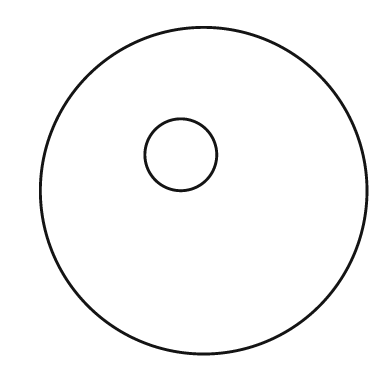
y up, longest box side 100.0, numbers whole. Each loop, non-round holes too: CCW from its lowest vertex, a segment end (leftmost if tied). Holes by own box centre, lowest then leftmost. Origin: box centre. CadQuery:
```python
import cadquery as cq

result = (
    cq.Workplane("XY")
    .moveTo(0.0, 0.0)
    .circle(50.0)
    .moveTo(-7.0, 11.0)
    .circle(11.0)
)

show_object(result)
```